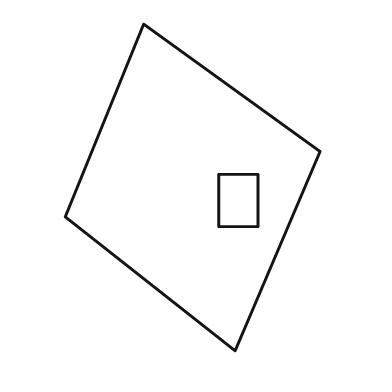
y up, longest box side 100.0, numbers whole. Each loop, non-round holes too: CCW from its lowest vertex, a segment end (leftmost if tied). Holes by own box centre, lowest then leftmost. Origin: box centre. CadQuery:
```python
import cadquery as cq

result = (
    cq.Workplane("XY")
    .moveTo(13.0, -50.0)
    .lineTo(39.0, 11.0)
    .lineTo(-15.0, 50.0)
    .lineTo(-39.0, -9.0)
    .close()
    .moveTo(8.0, -12.0)
    .lineTo(20.0, -12.0)
    .lineTo(20.0, 4.0)
    .lineTo(8.0, 4.0)
    .close()
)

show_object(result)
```